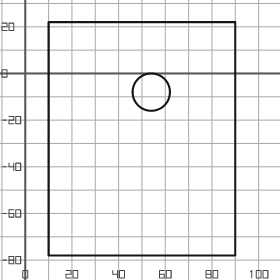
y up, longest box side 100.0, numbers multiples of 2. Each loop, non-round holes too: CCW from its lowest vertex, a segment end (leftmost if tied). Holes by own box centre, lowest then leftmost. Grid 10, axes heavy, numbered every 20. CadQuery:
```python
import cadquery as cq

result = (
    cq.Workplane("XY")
    .moveTo(10.0, -78.0)
    .lineTo(90.0, -78.0)
    .lineTo(90.0, 22.0)
    .lineTo(10.0, 22.0)
    .close()
    .moveTo(54.0, -8.0)
    .circle(8.0)
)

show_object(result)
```